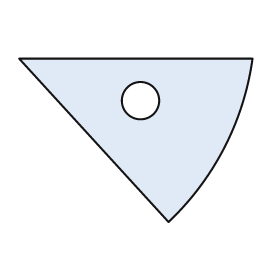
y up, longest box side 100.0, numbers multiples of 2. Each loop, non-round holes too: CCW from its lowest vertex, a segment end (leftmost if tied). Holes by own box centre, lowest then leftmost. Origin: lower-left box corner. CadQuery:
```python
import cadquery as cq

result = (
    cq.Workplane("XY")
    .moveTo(64.0, 0.0)
    .threePointArc((88.0, 32.0), (100.0, 70.0))
    .lineTo(0.0, 70.0)
    .close()
    .moveTo(52.0, 52.0)
    .circle(8.0)
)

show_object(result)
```